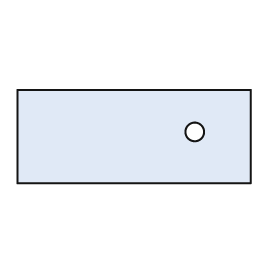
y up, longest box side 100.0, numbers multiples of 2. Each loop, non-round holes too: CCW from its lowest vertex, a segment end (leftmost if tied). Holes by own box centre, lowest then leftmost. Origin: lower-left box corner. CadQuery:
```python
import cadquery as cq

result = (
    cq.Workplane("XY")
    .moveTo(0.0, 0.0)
    .lineTo(100.0, 0.0)
    .lineTo(100.0, 40.0)
    .lineTo(0.0, 40.0)
    .close()
    .moveTo(76.0, 22.0)
    .circle(4.0)
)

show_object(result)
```